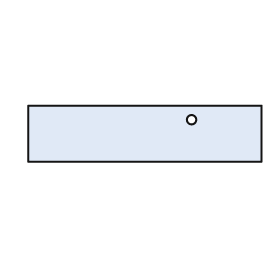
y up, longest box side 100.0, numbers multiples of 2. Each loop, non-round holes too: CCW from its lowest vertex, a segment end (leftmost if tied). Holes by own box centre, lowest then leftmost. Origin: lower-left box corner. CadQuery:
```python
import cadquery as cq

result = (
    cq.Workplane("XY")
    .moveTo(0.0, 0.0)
    .lineTo(100.0, 0.0)
    .lineTo(100.0, 24.0)
    .lineTo(0.0, 24.0)
    .close()
    .moveTo(70.0, 18.0)
    .circle(2.0)
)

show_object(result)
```